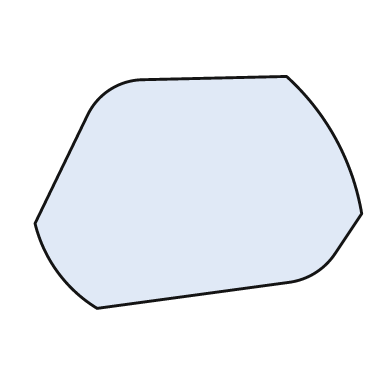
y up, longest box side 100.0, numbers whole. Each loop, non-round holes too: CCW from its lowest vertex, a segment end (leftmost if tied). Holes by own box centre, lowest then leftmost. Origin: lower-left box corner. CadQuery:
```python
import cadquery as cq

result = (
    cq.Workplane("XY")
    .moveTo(19.0, 0.0)
    .lineTo(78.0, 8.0)
    .threePointArc((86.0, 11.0), (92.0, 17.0))
    .lineTo(100.0, 29.0)
    .threePointArc((92.0, 52.0), (77.0, 71.0))
    .lineTo(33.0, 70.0)
    .threePointArc((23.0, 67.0), (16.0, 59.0))
    .lineTo(0.0, 26.0)
    .threePointArc((7.0, 11.0), (19.0, 0.0))
    .close()
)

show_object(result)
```